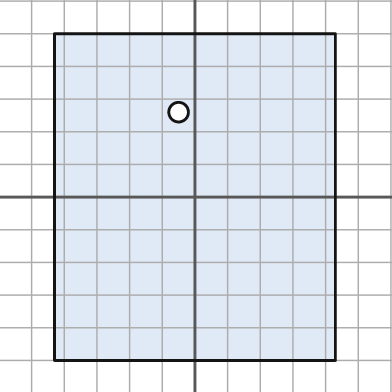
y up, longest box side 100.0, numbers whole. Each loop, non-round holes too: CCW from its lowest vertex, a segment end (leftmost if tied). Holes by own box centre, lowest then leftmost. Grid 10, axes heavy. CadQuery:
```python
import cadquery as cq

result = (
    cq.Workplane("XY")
    .moveTo(-43.0, -50.0)
    .lineTo(43.0, -50.0)
    .lineTo(43.0, 50.0)
    .lineTo(-43.0, 50.0)
    .close()
    .moveTo(-5.0, 26.0)
    .circle(3.0)
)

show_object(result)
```